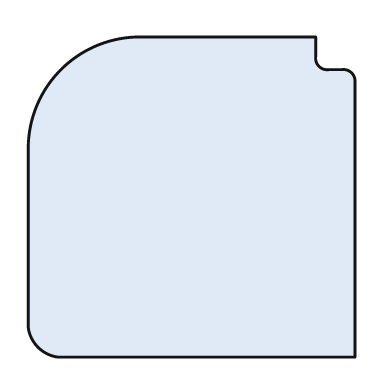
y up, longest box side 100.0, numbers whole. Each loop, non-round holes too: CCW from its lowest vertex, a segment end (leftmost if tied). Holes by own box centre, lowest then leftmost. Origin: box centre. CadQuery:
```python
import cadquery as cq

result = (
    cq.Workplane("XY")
    .moveTo(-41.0, -49.0)
    .lineTo(50.0, -49.0)
    .lineTo(50.0, 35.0)
    .threePointArc((49.0, 38.0), (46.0, 39.0))
    .lineTo(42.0, 39.0)
    .threePointArc((39.0, 40.0), (38.0, 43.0))
    .lineTo(38.0, 49.0)
    .lineTo(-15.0, 49.0)
    .threePointArc((-40.0, 39.0), (-50.0, 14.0))
    .lineTo(-50.0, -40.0)
    .threePointArc((-47.0, -46.0), (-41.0, -49.0))
    .close()
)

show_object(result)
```